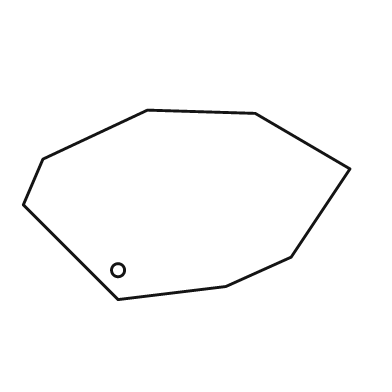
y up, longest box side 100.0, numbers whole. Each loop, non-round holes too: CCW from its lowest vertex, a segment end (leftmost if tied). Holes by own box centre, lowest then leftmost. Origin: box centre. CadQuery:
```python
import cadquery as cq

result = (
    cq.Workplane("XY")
    .moveTo(-21.0, -29.0)
    .lineTo(12.0, -25.0)
    .lineTo(32.0, -16.0)
    .lineTo(50.0, 11.0)
    .lineTo(21.0, 28.0)
    .lineTo(-12.0, 29.0)
    .lineTo(-44.0, 14.0)
    .lineTo(-50.0, 0.0)
    .close()
    .moveTo(-21.0, -20.0)
    .circle(2.0)
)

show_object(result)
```